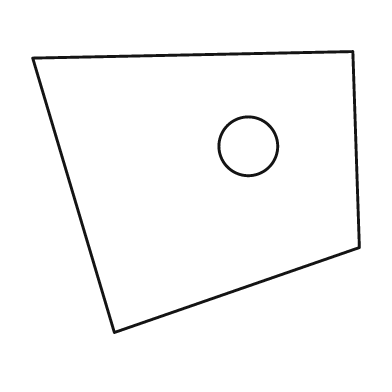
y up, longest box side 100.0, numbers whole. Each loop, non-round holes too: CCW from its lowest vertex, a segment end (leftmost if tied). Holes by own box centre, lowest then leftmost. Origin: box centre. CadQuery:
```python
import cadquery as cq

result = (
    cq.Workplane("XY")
    .moveTo(-25.0, -43.0)
    .lineTo(50.0, -17.0)
    .lineTo(48.0, 43.0)
    .lineTo(-50.0, 41.0)
    .close()
    .moveTo(16.0, 14.0)
    .circle(9.0)
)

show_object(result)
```